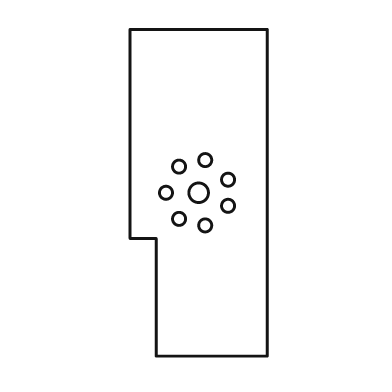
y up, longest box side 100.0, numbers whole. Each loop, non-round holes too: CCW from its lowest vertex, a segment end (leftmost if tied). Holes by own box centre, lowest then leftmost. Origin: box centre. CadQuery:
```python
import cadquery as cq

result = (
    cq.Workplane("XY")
    .moveTo(-13.0, -50.0)
    .lineTo(21.0, -50.0)
    .lineTo(21.0, 50.0)
    .lineTo(-21.0, 50.0)
    .lineTo(-21.0, -14.0)
    .lineTo(-13.0, -14.0)
    .close()
    .moveTo(2.0, -10.0)
    .circle(2.0)
    .moveTo(-6.0, -8.0)
    .circle(2.0)
    .moveTo(9.0, -4.0)
    .circle(2.0)
    .moveTo(-10.0, 0.0)
    .circle(2.0)
    .moveTo(0.0, 0.0)
    .circle(3.0)
    .moveTo(9.0, 4.0)
    .circle(2.0)
    .moveTo(-6.0, 8.0)
    .circle(2.0)
    .moveTo(2.0, 10.0)
    .circle(2.0)
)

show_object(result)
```